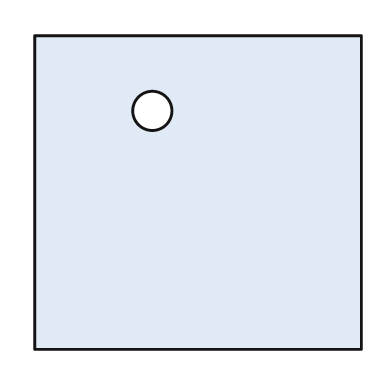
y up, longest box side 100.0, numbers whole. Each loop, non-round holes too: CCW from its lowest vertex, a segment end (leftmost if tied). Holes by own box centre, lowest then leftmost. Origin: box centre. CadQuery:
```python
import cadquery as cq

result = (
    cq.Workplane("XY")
    .moveTo(-50.0, -48.0)
    .lineTo(50.0, -48.0)
    .lineTo(50.0, 48.0)
    .lineTo(-50.0, 48.0)
    .close()
    .moveTo(-14.0, 25.0)
    .circle(6.0)
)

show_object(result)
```